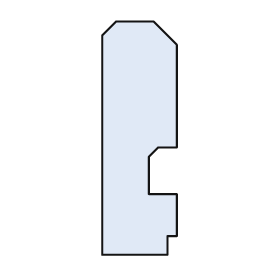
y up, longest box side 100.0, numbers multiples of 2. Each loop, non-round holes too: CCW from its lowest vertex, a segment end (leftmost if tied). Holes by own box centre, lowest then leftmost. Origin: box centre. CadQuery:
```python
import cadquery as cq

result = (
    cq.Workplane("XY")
    .moveTo(-16.0, -50.0)
    .lineTo(12.0, -50.0)
    .lineTo(12.0, -42.0)
    .lineTo(16.0, -42.0)
    .lineTo(16.0, -24.0)
    .lineTo(4.0, -24.0)
    .lineTo(4.0, -8.0)
    .lineTo(8.0, -4.0)
    .lineTo(16.0, -4.0)
    .lineTo(16.0, 40.0)
    .lineTo(6.0, 50.0)
    .lineTo(-10.0, 50.0)
    .lineTo(-16.0, 44.0)
    .close()
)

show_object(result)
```